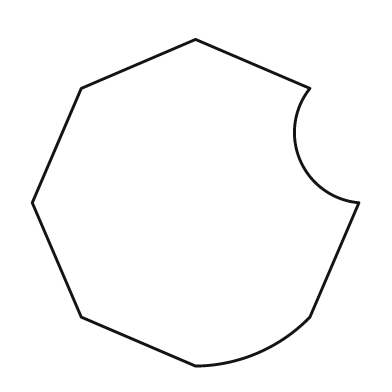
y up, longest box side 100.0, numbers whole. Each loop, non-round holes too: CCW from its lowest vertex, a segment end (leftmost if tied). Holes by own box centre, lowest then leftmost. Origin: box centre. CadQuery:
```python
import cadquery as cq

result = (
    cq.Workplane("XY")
    .moveTo(0.0, -50.0)
    .threePointArc((19.0, -46.0), (35.0, -35.0))
    .lineTo(50.0, 0.0)
    .threePointArc((32.0, 13.0), (35.0, 35.0))
    .lineTo(0.0, 50.0)
    .lineTo(-35.0, 35.0)
    .lineTo(-50.0, 0.0)
    .lineTo(-35.0, -35.0)
    .close()
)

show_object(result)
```